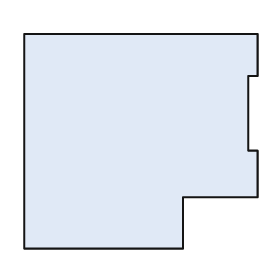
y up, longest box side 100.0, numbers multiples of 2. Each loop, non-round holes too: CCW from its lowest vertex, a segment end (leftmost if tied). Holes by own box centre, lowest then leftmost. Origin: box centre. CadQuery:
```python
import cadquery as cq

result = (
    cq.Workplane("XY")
    .moveTo(-50.0, -46.0)
    .lineTo(18.0, -46.0)
    .lineTo(18.0, -24.0)
    .lineTo(50.0, -24.0)
    .lineTo(50.0, -4.0)
    .lineTo(46.0, -4.0)
    .lineTo(46.0, 28.0)
    .lineTo(50.0, 28.0)
    .lineTo(50.0, 46.0)
    .lineTo(-50.0, 46.0)
    .close()
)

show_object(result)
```